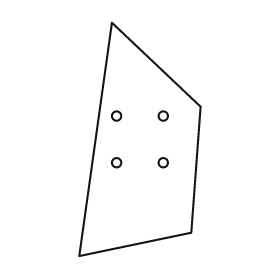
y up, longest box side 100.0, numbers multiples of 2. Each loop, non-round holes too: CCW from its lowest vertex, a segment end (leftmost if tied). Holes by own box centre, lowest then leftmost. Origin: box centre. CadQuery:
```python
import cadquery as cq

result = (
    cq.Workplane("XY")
    .moveTo(-26.0, -50.0)
    .lineTo(22.0, -40.0)
    .lineTo(26.0, 14.0)
    .lineTo(-12.0, 50.0)
    .close()
    .moveTo(-10.0, -10.0)
    .circle(2.0)
    .moveTo(10.0, -10.0)
    .circle(2.0)
    .moveTo(-10.0, 10.0)
    .circle(2.0)
    .moveTo(10.0, 10.0)
    .circle(2.0)
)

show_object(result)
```